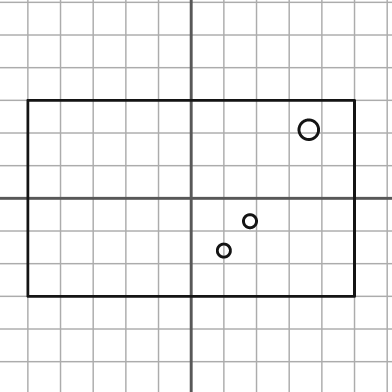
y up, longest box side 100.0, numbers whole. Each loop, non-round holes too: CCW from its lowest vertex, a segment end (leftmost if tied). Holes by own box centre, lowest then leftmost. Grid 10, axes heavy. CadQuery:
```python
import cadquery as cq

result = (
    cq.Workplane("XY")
    .moveTo(-50.0, -30.0)
    .lineTo(50.0, -30.0)
    .lineTo(50.0, 30.0)
    .lineTo(-50.0, 30.0)
    .close()
    .moveTo(10.0, -16.0)
    .circle(2.0)
    .moveTo(18.0, -7.0)
    .circle(2.0)
    .moveTo(36.0, 21.0)
    .circle(3.0)
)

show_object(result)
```